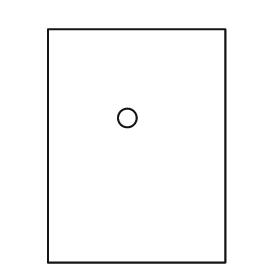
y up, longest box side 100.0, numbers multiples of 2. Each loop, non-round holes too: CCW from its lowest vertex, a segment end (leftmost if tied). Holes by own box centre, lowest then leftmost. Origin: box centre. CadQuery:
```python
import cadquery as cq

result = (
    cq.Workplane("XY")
    .moveTo(-38.0, -50.0)
    .lineTo(38.0, -50.0)
    .lineTo(38.0, 50.0)
    .lineTo(-38.0, 50.0)
    .close()
    .moveTo(-4.0, 12.0)
    .circle(4.0)
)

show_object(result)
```